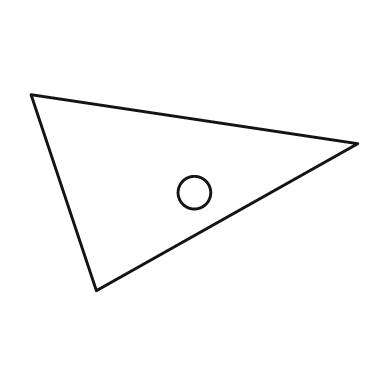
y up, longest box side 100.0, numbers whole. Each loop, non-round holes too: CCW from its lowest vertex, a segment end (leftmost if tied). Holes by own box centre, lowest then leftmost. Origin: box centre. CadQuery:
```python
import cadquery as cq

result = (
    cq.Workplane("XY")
    .moveTo(-30.0, -30.0)
    .lineTo(50.0, 15.0)
    .lineTo(-50.0, 30.0)
    .close()
    .moveTo(0.0, 0.0)
    .circle(5.0)
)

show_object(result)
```